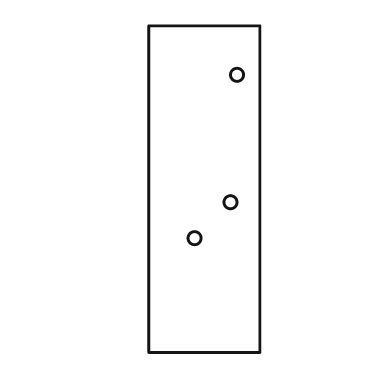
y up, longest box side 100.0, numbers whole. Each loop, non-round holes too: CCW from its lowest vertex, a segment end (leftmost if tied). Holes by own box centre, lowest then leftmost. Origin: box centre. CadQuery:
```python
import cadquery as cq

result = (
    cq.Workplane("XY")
    .moveTo(-17.0, -50.0)
    .lineTo(17.0, -50.0)
    .lineTo(17.0, 50.0)
    .lineTo(-17.0, 50.0)
    .close()
    .moveTo(-3.0, -15.0)
    .circle(2.0)
    .moveTo(8.0, -4.0)
    .circle(2.0)
    .moveTo(10.0, 35.0)
    .circle(2.0)
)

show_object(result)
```